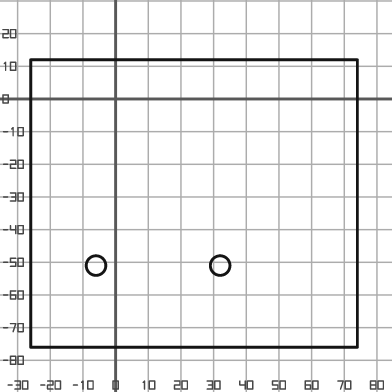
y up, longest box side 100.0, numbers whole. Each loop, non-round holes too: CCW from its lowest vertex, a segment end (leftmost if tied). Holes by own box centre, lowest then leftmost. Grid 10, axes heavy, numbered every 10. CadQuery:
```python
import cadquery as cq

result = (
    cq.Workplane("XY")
    .moveTo(-26.0, -76.0)
    .lineTo(74.0, -76.0)
    .lineTo(74.0, 12.0)
    .lineTo(-26.0, 12.0)
    .close()
    .moveTo(-6.0, -51.0)
    .circle(3.0)
    .moveTo(32.0, -51.0)
    .circle(3.0)
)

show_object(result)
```